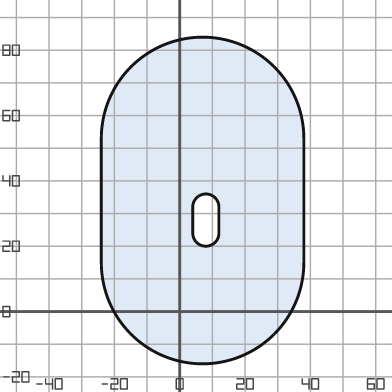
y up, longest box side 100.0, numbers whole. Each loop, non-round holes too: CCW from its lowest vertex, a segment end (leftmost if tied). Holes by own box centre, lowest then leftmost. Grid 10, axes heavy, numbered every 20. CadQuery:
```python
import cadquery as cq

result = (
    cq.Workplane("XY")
    .moveTo(-24.0, 15.0)
    .threePointArc((7.0, -16.0), (38.0, 15.0))
    .lineTo(38.0, 53.0)
    .threePointArc((7.0, 84.0), (-24.0, 53.0))
    .close()
    .moveTo(4.0, 24.0)
    .threePointArc((8.0, 20.0), (12.0, 24.0))
    .lineTo(12.0, 32.0)
    .threePointArc((8.0, 36.0), (4.0, 32.0))
    .close()
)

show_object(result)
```